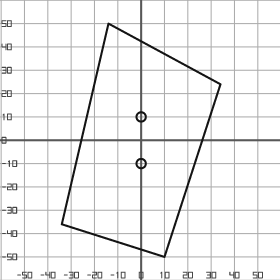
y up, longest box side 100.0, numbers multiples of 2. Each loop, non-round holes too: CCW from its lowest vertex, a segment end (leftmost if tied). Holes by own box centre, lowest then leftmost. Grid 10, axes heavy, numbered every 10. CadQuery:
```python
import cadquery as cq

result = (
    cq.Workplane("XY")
    .moveTo(10.0, -50.0)
    .lineTo(34.0, 24.0)
    .lineTo(-14.0, 50.0)
    .lineTo(-34.0, -36.0)
    .close()
    .moveTo(0.0, -10.0)
    .circle(2.0)
    .moveTo(0.0, 10.0)
    .circle(2.0)
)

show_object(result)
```